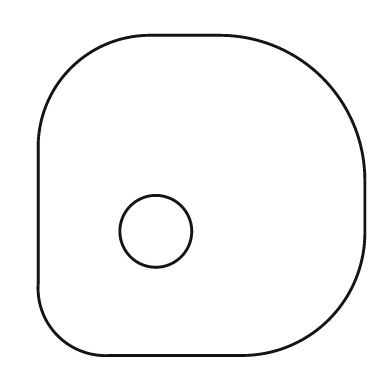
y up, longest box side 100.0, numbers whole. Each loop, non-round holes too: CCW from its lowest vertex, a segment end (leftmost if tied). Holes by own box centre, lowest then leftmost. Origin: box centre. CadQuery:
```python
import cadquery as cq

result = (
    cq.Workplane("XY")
    .moveTo(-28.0, -49.0)
    .lineTo(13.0, -49.0)
    .threePointArc((39.0, -38.0), (50.0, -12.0))
    .lineTo(50.0, 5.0)
    .threePointArc((37.0, 36.0), (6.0, 49.0))
    .lineTo(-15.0, 49.0)
    .threePointArc((-40.0, 39.0), (-50.0, 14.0))
    .lineTo(-50.0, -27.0)
    .threePointArc((-44.0, -43.0), (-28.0, -49.0))
    .close()
    .moveTo(-14.0, -11.0)
    .circle(11.0)
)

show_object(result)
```